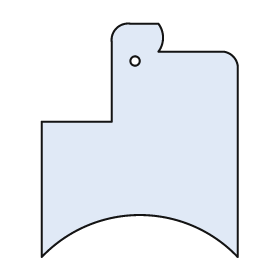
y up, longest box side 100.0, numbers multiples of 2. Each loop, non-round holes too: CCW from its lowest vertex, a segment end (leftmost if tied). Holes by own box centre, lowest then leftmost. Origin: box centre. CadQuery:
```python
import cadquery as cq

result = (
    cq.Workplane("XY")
    .moveTo(-42.0, -50.0)
    .threePointArc((0.0, -32.0), (42.0, -50.0))
    .lineTo(42.0, 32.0)
    .threePointArc((40.0, 36.0), (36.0, 38.0))
    .lineTo(8.0, 38.0)
    .threePointArc((10.0, 44.0), (8.0, 50.0))
    .lineTo(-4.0, 50.0)
    .threePointArc((-10.0, 48.0), (-12.0, 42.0))
    .lineTo(-12.0, 8.0)
    .lineTo(-42.0, 8.0)
    .close()
    .moveTo(-2.0, 34.0)
    .circle(2.0)
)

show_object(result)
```